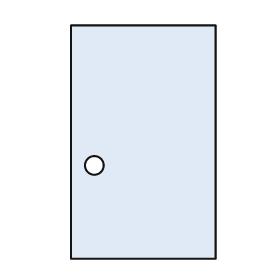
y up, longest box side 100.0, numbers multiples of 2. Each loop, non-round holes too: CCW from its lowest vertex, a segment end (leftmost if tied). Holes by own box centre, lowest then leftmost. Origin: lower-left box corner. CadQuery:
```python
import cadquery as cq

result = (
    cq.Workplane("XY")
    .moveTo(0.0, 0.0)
    .lineTo(62.0, 0.0)
    .lineTo(62.0, 100.0)
    .lineTo(0.0, 100.0)
    .close()
    .moveTo(10.0, 40.0)
    .circle(4.0)
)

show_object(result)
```